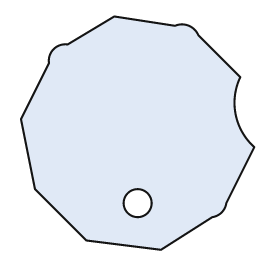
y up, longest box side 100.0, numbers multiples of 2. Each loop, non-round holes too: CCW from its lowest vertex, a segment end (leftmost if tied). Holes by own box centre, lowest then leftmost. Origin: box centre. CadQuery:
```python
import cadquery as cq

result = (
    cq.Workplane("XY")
    .moveTo(10.0, -50.0)
    .lineTo(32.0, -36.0)
    .threePointArc((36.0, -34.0), (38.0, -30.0))
    .lineTo(50.0, -6.0)
    .threePointArc((42.0, 8.0), (44.0, 24.0))
    .lineTo(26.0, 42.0)
    .threePointArc((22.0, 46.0), (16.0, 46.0))
    .lineTo(-10.0, 50.0)
    .lineTo(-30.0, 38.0)
    .threePointArc((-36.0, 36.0), (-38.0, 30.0))
    .lineTo(-50.0, 6.0)
    .lineTo(-44.0, -24.0)
    .lineTo(-22.0, -46.0)
    .close()
    .moveTo(0.0, -30.0)
    .circle(6.0)
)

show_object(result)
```